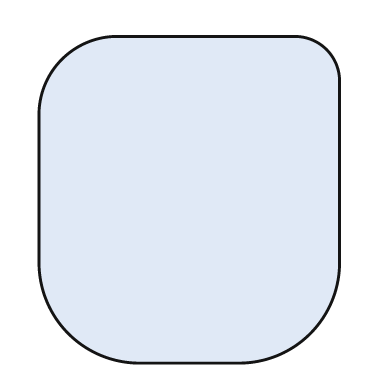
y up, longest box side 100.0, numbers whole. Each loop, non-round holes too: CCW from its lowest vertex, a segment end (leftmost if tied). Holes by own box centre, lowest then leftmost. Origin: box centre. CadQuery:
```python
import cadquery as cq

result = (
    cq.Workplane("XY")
    .moveTo(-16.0, -50.0)
    .lineTo(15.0, -50.0)
    .threePointArc((37.0, -41.0), (46.0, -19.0))
    .lineTo(46.0, 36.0)
    .threePointArc((42.0, 46.0), (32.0, 50.0))
    .lineTo(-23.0, 50.0)
    .threePointArc((-39.0, 43.0), (-46.0, 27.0))
    .lineTo(-46.0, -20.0)
    .threePointArc((-37.0, -41.0), (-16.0, -50.0))
    .close()
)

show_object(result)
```